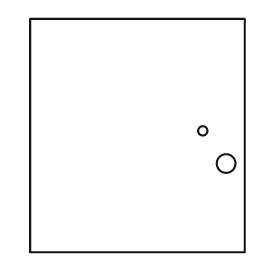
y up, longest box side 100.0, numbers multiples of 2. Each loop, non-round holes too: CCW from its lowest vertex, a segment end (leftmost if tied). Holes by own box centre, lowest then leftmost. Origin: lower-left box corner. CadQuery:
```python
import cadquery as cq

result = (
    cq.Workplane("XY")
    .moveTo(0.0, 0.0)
    .lineTo(92.0, 0.0)
    .lineTo(92.0, 100.0)
    .lineTo(0.0, 100.0)
    .close()
    .moveTo(84.0, 38.0)
    .circle(4.0)
    .moveTo(74.0, 52.0)
    .circle(2.0)
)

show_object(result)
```